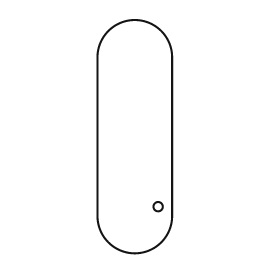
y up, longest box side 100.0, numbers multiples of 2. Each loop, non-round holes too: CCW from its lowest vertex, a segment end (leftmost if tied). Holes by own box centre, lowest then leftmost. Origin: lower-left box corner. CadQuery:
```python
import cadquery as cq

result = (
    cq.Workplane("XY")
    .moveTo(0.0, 16.0)
    .threePointArc((16.0, 0.0), (32.0, 16.0))
    .lineTo(32.0, 84.0)
    .threePointArc((16.0, 100.0), (0.0, 84.0))
    .close()
    .moveTo(26.0, 20.0)
    .circle(2.0)
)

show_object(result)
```